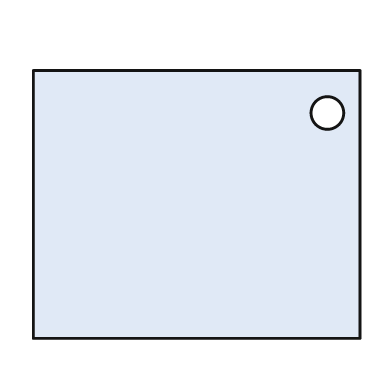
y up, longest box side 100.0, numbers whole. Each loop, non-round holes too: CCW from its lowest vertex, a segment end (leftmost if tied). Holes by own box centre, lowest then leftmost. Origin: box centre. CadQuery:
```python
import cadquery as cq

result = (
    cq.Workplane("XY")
    .moveTo(-50.0, -41.0)
    .lineTo(50.0, -41.0)
    .lineTo(50.0, 41.0)
    .lineTo(-50.0, 41.0)
    .close()
    .moveTo(40.0, 28.0)
    .circle(5.0)
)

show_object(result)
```